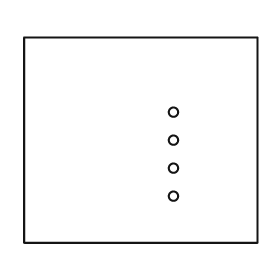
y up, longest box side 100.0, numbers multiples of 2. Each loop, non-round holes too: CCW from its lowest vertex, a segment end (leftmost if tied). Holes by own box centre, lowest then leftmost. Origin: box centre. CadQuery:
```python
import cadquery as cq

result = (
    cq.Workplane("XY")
    .moveTo(-50.0, -44.0)
    .lineTo(50.0, -44.0)
    .lineTo(50.0, 44.0)
    .lineTo(-50.0, 44.0)
    .close()
    .moveTo(14.0, -24.0)
    .circle(2.0)
    .moveTo(14.0, -12.0)
    .circle(2.0)
    .moveTo(14.0, 0.0)
    .circle(2.0)
    .moveTo(14.0, 12.0)
    .circle(2.0)
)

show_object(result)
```